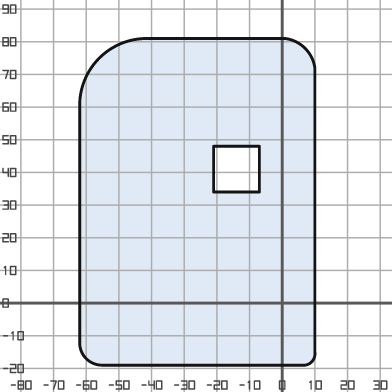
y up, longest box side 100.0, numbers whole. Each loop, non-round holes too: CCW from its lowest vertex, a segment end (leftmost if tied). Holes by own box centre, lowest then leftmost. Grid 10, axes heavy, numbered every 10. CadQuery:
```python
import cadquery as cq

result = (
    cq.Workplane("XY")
    .moveTo(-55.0, -19.0)
    .lineTo(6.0, -19.0)
    .threePointArc((9.0, -18.0), (10.0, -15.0))
    .lineTo(10.0, 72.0)
    .threePointArc((7.0, 78.0), (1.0, 81.0))
    .lineTo(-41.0, 81.0)
    .threePointArc((-56.0, 75.0), (-62.0, 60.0))
    .lineTo(-62.0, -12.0)
    .threePointArc((-60.0, -17.0), (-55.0, -19.0))
    .close()
    .moveTo(-21.0, 34.0)
    .lineTo(-7.0, 34.0)
    .lineTo(-7.0, 48.0)
    .lineTo(-21.0, 48.0)
    .close()
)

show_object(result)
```